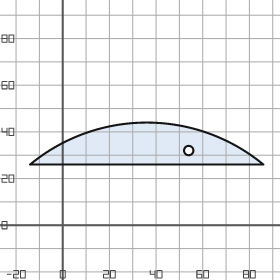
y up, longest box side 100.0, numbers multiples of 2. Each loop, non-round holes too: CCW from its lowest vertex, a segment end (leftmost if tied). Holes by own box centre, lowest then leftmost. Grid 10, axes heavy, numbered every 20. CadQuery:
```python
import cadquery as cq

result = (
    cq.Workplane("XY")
    .moveTo(-14.0, 26.0)
    .lineTo(86.0, 26.0)
    .threePointArc((36.0, 44.0), (-14.0, 26.0))
    .close()
    .moveTo(54.0, 32.0)
    .circle(2.0)
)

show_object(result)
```